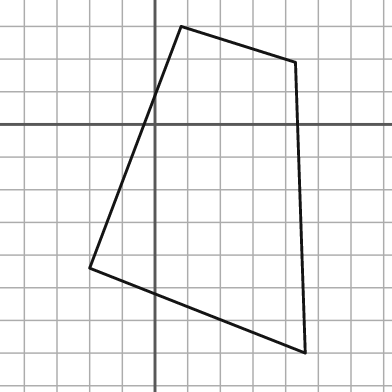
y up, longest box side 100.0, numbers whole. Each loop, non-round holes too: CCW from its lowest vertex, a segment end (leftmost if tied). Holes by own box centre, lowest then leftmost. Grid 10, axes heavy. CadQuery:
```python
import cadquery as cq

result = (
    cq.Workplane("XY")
    .moveTo(46.0, -70.0)
    .lineTo(43.0, 19.0)
    .lineTo(8.0, 30.0)
    .lineTo(-20.0, -44.0)
    .close()
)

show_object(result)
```